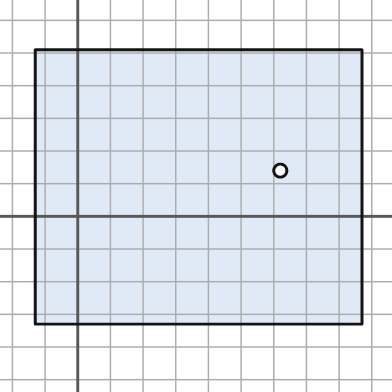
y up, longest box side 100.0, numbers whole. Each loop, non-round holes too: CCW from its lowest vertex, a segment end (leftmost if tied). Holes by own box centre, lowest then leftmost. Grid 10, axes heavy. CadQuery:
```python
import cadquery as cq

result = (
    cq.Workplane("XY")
    .moveTo(-13.0, -33.0)
    .lineTo(87.0, -33.0)
    .lineTo(87.0, 51.0)
    .lineTo(-13.0, 51.0)
    .close()
    .moveTo(62.0, 14.0)
    .circle(2.0)
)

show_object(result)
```